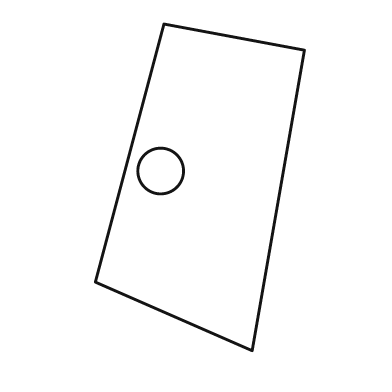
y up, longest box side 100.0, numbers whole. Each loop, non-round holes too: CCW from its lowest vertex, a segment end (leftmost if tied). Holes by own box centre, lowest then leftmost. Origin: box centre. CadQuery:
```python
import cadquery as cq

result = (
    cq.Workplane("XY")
    .moveTo(16.0, -50.0)
    .lineTo(32.0, 42.0)
    .lineTo(-11.0, 50.0)
    .lineTo(-32.0, -29.0)
    .close()
    .moveTo(-12.0, 5.0)
    .circle(7.0)
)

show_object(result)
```